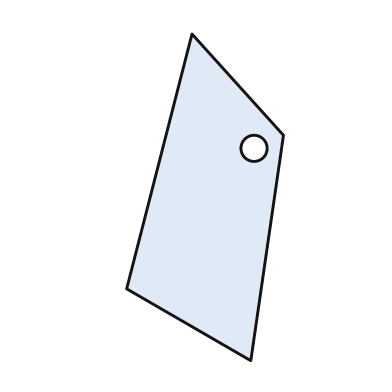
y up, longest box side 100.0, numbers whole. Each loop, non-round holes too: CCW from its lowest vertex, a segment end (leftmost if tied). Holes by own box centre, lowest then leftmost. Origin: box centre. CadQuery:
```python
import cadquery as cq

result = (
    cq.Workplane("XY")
    .moveTo(14.0, -50.0)
    .lineTo(24.0, 19.0)
    .lineTo(-4.0, 50.0)
    .lineTo(-24.0, -28.0)
    .close()
    .moveTo(15.0, 15.0)
    .circle(4.0)
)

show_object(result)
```